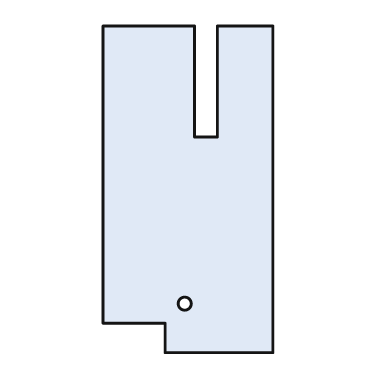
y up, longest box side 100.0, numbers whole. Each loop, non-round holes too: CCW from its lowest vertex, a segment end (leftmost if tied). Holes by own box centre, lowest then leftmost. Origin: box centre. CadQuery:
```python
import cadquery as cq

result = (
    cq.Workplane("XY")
    .moveTo(-7.0, -50.0)
    .lineTo(26.0, -50.0)
    .lineTo(26.0, 50.0)
    .lineTo(9.0, 50.0)
    .lineTo(9.0, 16.0)
    .lineTo(2.0, 16.0)
    .lineTo(2.0, 50.0)
    .lineTo(-26.0, 50.0)
    .lineTo(-26.0, -41.0)
    .lineTo(-7.0, -41.0)
    .close()
    .moveTo(-1.0, -35.0)
    .circle(2.0)
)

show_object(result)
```